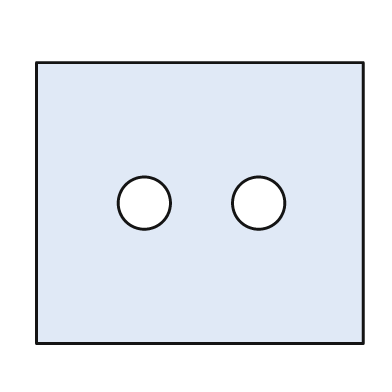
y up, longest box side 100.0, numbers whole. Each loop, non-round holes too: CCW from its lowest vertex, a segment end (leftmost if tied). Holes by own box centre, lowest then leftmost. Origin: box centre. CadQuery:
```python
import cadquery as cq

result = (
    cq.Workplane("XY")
    .moveTo(-50.0, -43.0)
    .lineTo(50.0, -43.0)
    .lineTo(50.0, 43.0)
    .lineTo(-50.0, 43.0)
    .close()
    .moveTo(-17.0, 0.0)
    .circle(8.0)
    .moveTo(18.0, 0.0)
    .circle(8.0)
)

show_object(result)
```